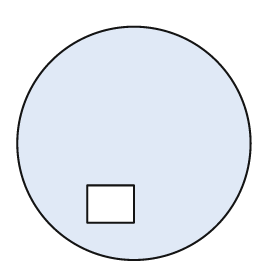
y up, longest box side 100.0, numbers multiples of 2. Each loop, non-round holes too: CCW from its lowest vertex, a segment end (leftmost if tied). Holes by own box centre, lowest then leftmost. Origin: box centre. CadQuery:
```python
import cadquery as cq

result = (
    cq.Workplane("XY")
    .moveTo(0.0, 0.0)
    .circle(50.0)
    .moveTo(-20.0, -34.0)
    .lineTo(0.0, -34.0)
    .lineTo(0.0, -18.0)
    .lineTo(-20.0, -18.0)
    .close()
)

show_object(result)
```